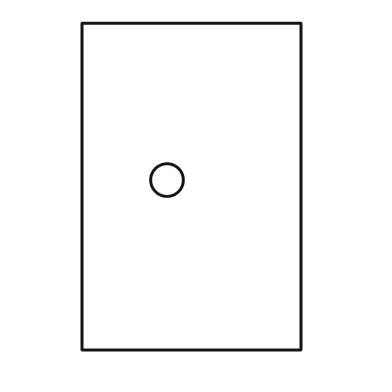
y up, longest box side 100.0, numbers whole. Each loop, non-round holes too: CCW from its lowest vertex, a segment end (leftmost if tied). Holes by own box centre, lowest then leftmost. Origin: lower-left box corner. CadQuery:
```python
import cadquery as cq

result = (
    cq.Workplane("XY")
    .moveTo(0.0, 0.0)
    .lineTo(67.0, 0.0)
    .lineTo(67.0, 100.0)
    .lineTo(0.0, 100.0)
    .close()
    .moveTo(26.0, 52.0)
    .circle(5.0)
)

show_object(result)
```